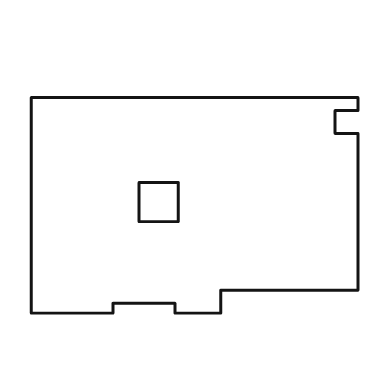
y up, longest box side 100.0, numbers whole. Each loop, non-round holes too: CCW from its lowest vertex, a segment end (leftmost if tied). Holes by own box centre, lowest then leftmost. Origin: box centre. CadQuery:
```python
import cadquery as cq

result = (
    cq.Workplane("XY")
    .moveTo(-50.0, -33.0)
    .lineTo(-25.0, -33.0)
    .lineTo(-25.0, -30.0)
    .lineTo(-6.0, -30.0)
    .lineTo(-6.0, -33.0)
    .lineTo(8.0, -33.0)
    .lineTo(8.0, -26.0)
    .lineTo(50.0, -26.0)
    .lineTo(50.0, 22.0)
    .lineTo(43.0, 22.0)
    .lineTo(43.0, 29.0)
    .lineTo(50.0, 29.0)
    .lineTo(50.0, 33.0)
    .lineTo(-50.0, 33.0)
    .close()
    .moveTo(-17.0, -5.0)
    .lineTo(-5.0, -5.0)
    .lineTo(-5.0, 7.0)
    .lineTo(-17.0, 7.0)
    .close()
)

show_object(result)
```